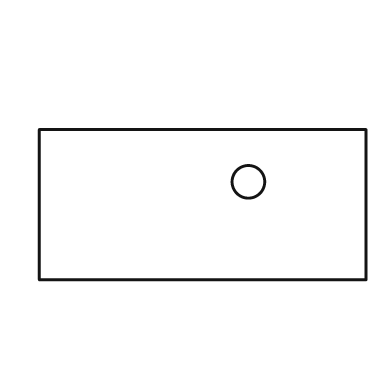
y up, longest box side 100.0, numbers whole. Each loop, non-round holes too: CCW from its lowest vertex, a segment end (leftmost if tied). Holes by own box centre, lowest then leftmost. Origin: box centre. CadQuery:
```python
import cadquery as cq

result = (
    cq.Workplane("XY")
    .moveTo(-50.0, -23.0)
    .lineTo(50.0, -23.0)
    .lineTo(50.0, 23.0)
    .lineTo(-50.0, 23.0)
    .close()
    .moveTo(14.0, 7.0)
    .circle(5.0)
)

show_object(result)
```